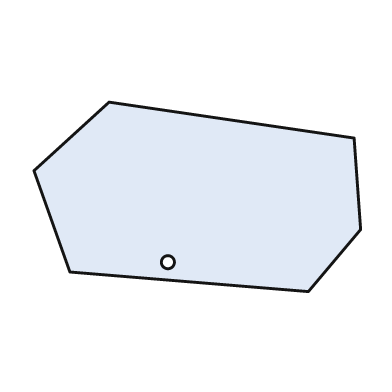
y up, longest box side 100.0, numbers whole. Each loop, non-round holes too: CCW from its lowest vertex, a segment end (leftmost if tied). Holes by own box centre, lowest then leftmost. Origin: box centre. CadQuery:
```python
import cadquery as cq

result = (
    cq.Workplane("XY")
    .moveTo(34.0, -29.0)
    .lineTo(50.0, -10.0)
    .lineTo(48.0, 18.0)
    .lineTo(-27.0, 29.0)
    .lineTo(-50.0, 8.0)
    .lineTo(-39.0, -23.0)
    .close()
    .moveTo(-9.0, -20.0)
    .circle(2.0)
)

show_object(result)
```